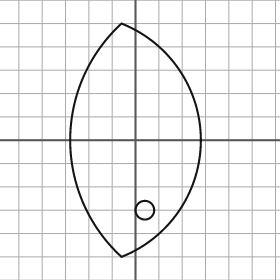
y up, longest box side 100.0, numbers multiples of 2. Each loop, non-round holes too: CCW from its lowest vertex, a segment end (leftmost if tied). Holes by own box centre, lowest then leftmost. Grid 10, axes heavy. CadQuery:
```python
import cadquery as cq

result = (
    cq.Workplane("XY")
    .moveTo(-6.0, -50.0)
    .threePointArc((28.0, 0.0), (-6.0, 50.0))
    .threePointArc((-28.0, 0.0), (-6.0, -50.0))
    .close()
    .moveTo(4.0, -30.0)
    .circle(4.0)
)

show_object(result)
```